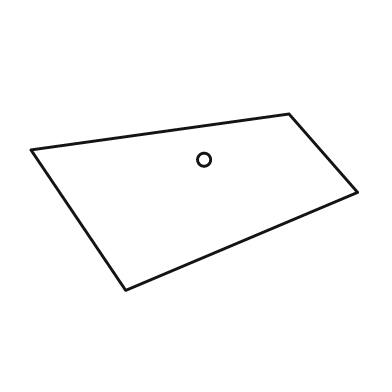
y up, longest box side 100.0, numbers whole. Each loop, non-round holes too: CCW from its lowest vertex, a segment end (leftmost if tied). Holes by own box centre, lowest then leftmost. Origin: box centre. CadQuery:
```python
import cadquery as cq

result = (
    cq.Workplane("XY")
    .moveTo(-21.0, -27.0)
    .lineTo(50.0, 3.0)
    .lineTo(29.0, 27.0)
    .lineTo(-50.0, 16.0)
    .close()
    .moveTo(3.0, 13.0)
    .circle(2.0)
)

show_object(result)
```